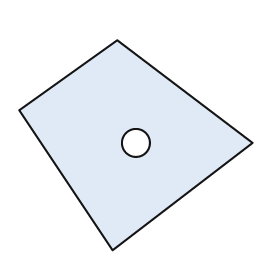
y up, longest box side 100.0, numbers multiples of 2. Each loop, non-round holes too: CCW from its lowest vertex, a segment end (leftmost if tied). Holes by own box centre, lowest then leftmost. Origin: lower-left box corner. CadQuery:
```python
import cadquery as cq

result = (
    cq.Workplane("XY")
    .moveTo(40.0, 0.0)
    .lineTo(100.0, 46.0)
    .lineTo(42.0, 90.0)
    .lineTo(0.0, 60.0)
    .close()
    .moveTo(50.0, 46.0)
    .circle(6.0)
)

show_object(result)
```